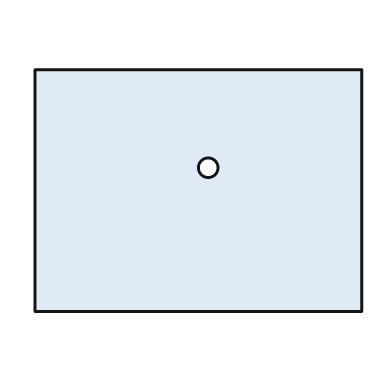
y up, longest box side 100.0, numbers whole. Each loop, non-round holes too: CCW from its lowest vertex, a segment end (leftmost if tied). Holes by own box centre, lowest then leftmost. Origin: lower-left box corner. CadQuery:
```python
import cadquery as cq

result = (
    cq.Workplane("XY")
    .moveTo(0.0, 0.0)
    .lineTo(100.0, 0.0)
    .lineTo(100.0, 74.0)
    .lineTo(0.0, 74.0)
    .close()
    .moveTo(53.0, 44.0)
    .circle(3.0)
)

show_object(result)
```